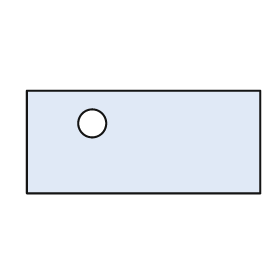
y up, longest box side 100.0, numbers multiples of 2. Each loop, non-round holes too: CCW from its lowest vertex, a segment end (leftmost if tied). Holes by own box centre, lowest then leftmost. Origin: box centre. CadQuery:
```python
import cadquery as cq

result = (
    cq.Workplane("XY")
    .moveTo(-50.0, -22.0)
    .lineTo(50.0, -22.0)
    .lineTo(50.0, 22.0)
    .lineTo(-50.0, 22.0)
    .close()
    .moveTo(-22.0, 8.0)
    .circle(6.0)
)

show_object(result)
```